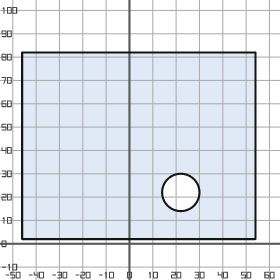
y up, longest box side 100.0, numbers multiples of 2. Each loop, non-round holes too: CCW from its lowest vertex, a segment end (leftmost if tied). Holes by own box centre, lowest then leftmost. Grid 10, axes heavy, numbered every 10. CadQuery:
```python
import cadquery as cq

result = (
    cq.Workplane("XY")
    .moveTo(-46.0, 2.0)
    .lineTo(54.0, 2.0)
    .lineTo(54.0, 82.0)
    .lineTo(-46.0, 82.0)
    .close()
    .moveTo(22.0, 22.0)
    .circle(8.0)
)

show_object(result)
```